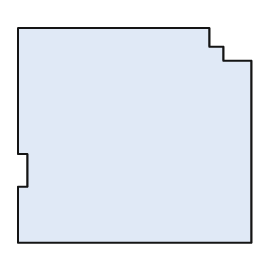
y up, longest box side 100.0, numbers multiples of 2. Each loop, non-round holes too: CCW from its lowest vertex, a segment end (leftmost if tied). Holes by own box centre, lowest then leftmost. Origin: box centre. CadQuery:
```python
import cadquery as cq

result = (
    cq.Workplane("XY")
    .moveTo(-50.0, -46.0)
    .lineTo(50.0, -46.0)
    .lineTo(50.0, 32.0)
    .lineTo(38.0, 32.0)
    .lineTo(38.0, 38.0)
    .lineTo(32.0, 38.0)
    .lineTo(32.0, 46.0)
    .lineTo(-50.0, 46.0)
    .lineTo(-50.0, -8.0)
    .lineTo(-46.0, -8.0)
    .lineTo(-46.0, -22.0)
    .lineTo(-50.0, -22.0)
    .close()
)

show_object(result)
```